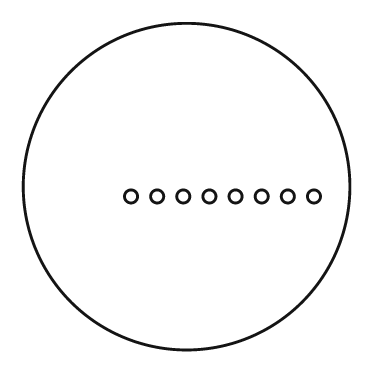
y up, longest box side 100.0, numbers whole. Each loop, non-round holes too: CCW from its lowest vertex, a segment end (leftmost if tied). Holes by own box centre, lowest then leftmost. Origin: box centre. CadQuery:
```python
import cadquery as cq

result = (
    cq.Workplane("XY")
    .moveTo(0.0, 0.0)
    .circle(50.0)
    .moveTo(-17.0, -3.0)
    .circle(2.0)
    .moveTo(-9.0, -3.0)
    .circle(2.0)
    .moveTo(-1.0, -3.0)
    .circle(2.0)
    .moveTo(7.0, -3.0)
    .circle(2.0)
    .moveTo(15.0, -3.0)
    .circle(2.0)
    .moveTo(23.0, -3.0)
    .circle(2.0)
    .moveTo(31.0, -3.0)
    .circle(2.0)
    .moveTo(39.0, -3.0)
    .circle(2.0)
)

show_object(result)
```